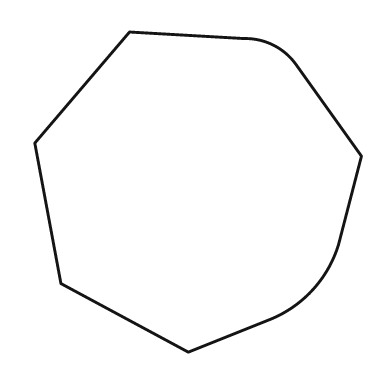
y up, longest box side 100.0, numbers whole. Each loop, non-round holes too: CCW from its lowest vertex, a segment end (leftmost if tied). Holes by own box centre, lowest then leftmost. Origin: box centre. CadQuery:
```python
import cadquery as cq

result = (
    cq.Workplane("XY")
    .moveTo(-3.0, -49.0)
    .lineTo(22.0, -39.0)
    .threePointArc((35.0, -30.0), (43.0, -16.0))
    .lineTo(50.0, 11.0)
    .lineTo(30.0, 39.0)
    .threePointArc((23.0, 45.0), (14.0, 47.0))
    .lineTo(-21.0, 49.0)
    .lineTo(-50.0, 15.0)
    .lineTo(-42.0, -28.0)
    .close()
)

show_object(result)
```